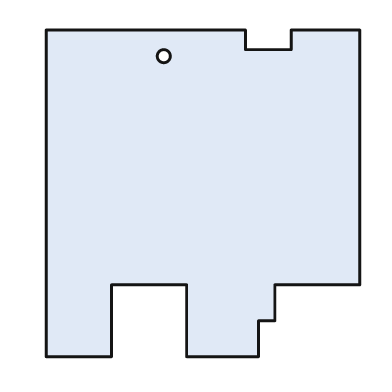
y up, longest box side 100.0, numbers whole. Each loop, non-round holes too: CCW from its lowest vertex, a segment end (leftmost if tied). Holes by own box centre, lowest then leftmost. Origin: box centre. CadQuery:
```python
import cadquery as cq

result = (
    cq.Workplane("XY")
    .moveTo(-48.0, -50.0)
    .lineTo(-28.0, -50.0)
    .lineTo(-28.0, -28.0)
    .lineTo(-5.0, -28.0)
    .lineTo(-5.0, -50.0)
    .lineTo(17.0, -50.0)
    .lineTo(17.0, -39.0)
    .lineTo(22.0, -39.0)
    .lineTo(22.0, -28.0)
    .lineTo(48.0, -28.0)
    .lineTo(48.0, 50.0)
    .lineTo(27.0, 50.0)
    .lineTo(27.0, 44.0)
    .lineTo(13.0, 44.0)
    .lineTo(13.0, 50.0)
    .lineTo(-48.0, 50.0)
    .close()
    .moveTo(-12.0, 42.0)
    .circle(2.0)
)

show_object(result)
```